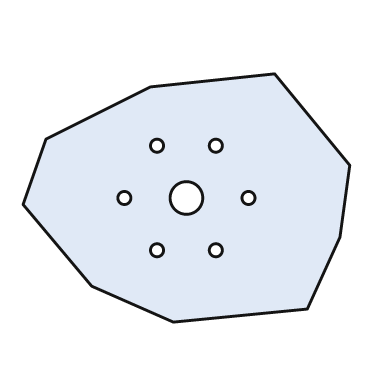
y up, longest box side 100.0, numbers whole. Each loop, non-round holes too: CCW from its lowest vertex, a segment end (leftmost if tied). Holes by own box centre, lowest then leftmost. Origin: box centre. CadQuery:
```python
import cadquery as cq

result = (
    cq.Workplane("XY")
    .moveTo(-4.0, -38.0)
    .lineTo(37.0, -34.0)
    .lineTo(47.0, -12.0)
    .lineTo(50.0, 10.0)
    .lineTo(27.0, 38.0)
    .lineTo(-11.0, 34.0)
    .lineTo(-43.0, 18.0)
    .lineTo(-50.0, -2.0)
    .lineTo(-29.0, -27.0)
    .close()
    .moveTo(-9.0, -16.0)
    .circle(2.0)
    .moveTo(9.0, -16.0)
    .circle(2.0)
    .moveTo(-19.0, 0.0)
    .circle(2.0)
    .moveTo(0.0, 0.0)
    .circle(5.0)
    .moveTo(19.0, 0.0)
    .circle(2.0)
    .moveTo(-9.0, 16.0)
    .circle(2.0)
    .moveTo(9.0, 16.0)
    .circle(2.0)
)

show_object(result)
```